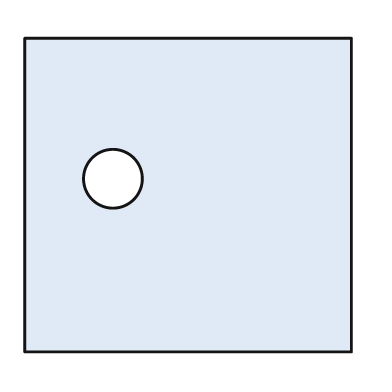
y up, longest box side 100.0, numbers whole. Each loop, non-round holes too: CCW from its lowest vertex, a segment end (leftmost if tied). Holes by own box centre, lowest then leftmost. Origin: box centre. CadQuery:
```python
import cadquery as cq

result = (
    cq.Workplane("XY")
    .moveTo(-50.0, -48.0)
    .lineTo(50.0, -48.0)
    .lineTo(50.0, 48.0)
    .lineTo(-50.0, 48.0)
    .close()
    .moveTo(-23.0, 5.0)
    .circle(9.0)
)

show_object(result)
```